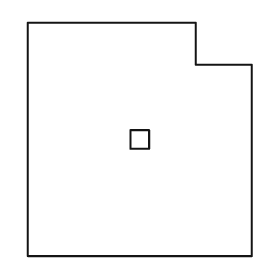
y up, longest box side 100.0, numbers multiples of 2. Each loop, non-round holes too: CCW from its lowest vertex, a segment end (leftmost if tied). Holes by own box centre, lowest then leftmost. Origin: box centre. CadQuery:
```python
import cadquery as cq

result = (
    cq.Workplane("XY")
    .moveTo(-48.0, -50.0)
    .lineTo(48.0, -50.0)
    .lineTo(48.0, 32.0)
    .lineTo(24.0, 32.0)
    .lineTo(24.0, 50.0)
    .lineTo(-48.0, 50.0)
    .close()
    .moveTo(-4.0, -4.0)
    .lineTo(4.0, -4.0)
    .lineTo(4.0, 4.0)
    .lineTo(-4.0, 4.0)
    .close()
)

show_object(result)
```